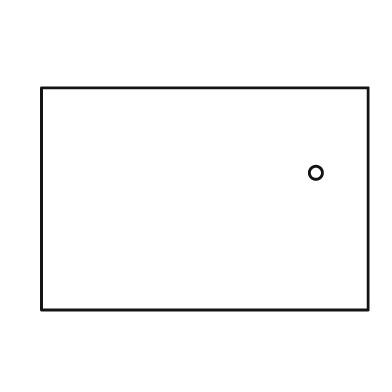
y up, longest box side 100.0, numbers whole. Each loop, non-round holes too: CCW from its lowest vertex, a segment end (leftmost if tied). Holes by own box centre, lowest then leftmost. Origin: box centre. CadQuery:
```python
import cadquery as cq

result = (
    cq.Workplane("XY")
    .moveTo(-50.0, -34.0)
    .lineTo(50.0, -34.0)
    .lineTo(50.0, 34.0)
    .lineTo(-50.0, 34.0)
    .close()
    .moveTo(34.0, 8.0)
    .circle(2.0)
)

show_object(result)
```